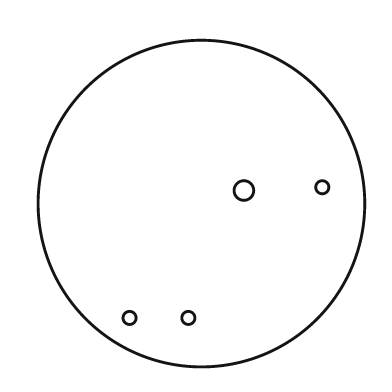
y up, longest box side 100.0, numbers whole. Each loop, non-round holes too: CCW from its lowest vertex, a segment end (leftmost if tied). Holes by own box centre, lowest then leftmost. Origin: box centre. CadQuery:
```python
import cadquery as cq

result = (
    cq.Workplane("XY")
    .moveTo(0.0, 0.0)
    .circle(50.0)
    .moveTo(-22.0, -35.0)
    .circle(2.0)
    .moveTo(-4.0, -35.0)
    .circle(2.0)
    .moveTo(13.0, 4.0)
    .circle(3.0)
    .moveTo(37.0, 5.0)
    .circle(2.0)
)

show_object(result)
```